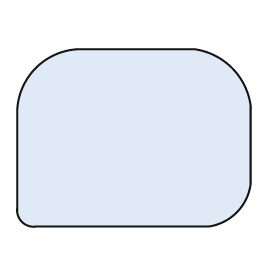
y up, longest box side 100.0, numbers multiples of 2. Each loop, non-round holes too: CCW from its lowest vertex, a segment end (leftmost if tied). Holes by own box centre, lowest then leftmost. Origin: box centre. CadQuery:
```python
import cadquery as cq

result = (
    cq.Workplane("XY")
    .moveTo(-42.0, -38.0)
    .lineTo(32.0, -38.0)
    .threePointArc((44.0, -32.0), (50.0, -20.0))
    .lineTo(50.0, 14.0)
    .threePointArc((42.0, 30.0), (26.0, 38.0))
    .lineTo(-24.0, 38.0)
    .threePointArc((-42.0, 30.0), (-50.0, 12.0))
    .lineTo(-50.0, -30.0)
    .threePointArc((-48.0, -36.0), (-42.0, -38.0))
    .close()
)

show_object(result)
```